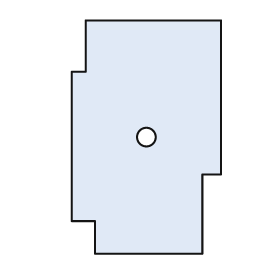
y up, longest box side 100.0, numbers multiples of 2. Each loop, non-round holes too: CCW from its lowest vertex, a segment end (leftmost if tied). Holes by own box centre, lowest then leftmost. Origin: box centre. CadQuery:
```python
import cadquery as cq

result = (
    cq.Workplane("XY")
    .moveTo(-22.0, -50.0)
    .lineTo(24.0, -50.0)
    .lineTo(24.0, -16.0)
    .lineTo(32.0, -16.0)
    .lineTo(32.0, 50.0)
    .lineTo(-26.0, 50.0)
    .lineTo(-26.0, 28.0)
    .lineTo(-32.0, 28.0)
    .lineTo(-32.0, -36.0)
    .lineTo(-22.0, -36.0)
    .close()
    .moveTo(0.0, 0.0)
    .circle(4.0)
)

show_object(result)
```